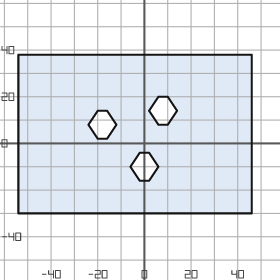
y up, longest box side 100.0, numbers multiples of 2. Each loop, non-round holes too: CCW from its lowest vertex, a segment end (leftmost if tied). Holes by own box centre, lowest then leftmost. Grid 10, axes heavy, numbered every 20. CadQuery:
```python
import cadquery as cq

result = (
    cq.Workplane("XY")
    .moveTo(-54.0, -30.0)
    .lineTo(46.0, -30.0)
    .lineTo(46.0, 38.0)
    .lineTo(-54.0, 38.0)
    .close()
    .moveTo(-2.0, -16.0)
    .lineTo(2.0, -16.0)
    .lineTo(6.0, -10.0)
    .lineTo(2.0, -4.0)
    .lineTo(-2.0, -4.0)
    .lineTo(-6.0, -10.0)
    .close()
    .moveTo(-20.0, 2.0)
    .lineTo(-16.0, 2.0)
    .lineTo(-12.0, 8.0)
    .lineTo(-16.0, 14.0)
    .lineTo(-20.0, 14.0)
    .lineTo(-24.0, 8.0)
    .close()
    .moveTo(6.0, 8.0)
    .lineTo(10.0, 8.0)
    .lineTo(14.0, 14.0)
    .lineTo(10.0, 20.0)
    .lineTo(6.0, 20.0)
    .lineTo(2.0, 14.0)
    .close()
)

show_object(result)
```